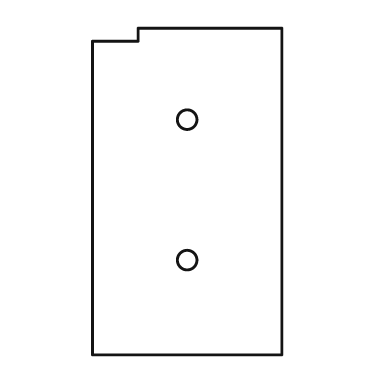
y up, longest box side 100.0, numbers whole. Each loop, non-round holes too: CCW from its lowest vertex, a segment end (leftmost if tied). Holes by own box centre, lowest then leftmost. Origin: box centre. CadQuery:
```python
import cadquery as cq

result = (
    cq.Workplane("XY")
    .moveTo(-29.0, -50.0)
    .lineTo(29.0, -50.0)
    .lineTo(29.0, 50.0)
    .lineTo(-15.0, 50.0)
    .lineTo(-15.0, 46.0)
    .lineTo(-29.0, 46.0)
    .close()
    .moveTo(0.0, -21.0)
    .circle(3.0)
    .moveTo(0.0, 22.0)
    .circle(3.0)
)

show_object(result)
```